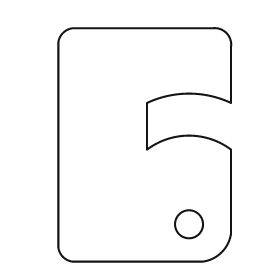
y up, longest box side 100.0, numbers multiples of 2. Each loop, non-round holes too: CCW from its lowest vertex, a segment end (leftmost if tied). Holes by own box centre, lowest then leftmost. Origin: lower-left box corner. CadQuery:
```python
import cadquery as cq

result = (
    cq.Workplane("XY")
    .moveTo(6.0, 0.0)
    .lineTo(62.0, 0.0)
    .threePointArc((70.0, 4.0), (74.0, 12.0))
    .lineTo(74.0, 48.0)
    .threePointArc((56.0, 54.0), (38.0, 48.0))
    .lineTo(38.0, 68.0)
    .threePointArc((56.0, 72.0), (74.0, 68.0))
    .lineTo(74.0, 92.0)
    .threePointArc((72.0, 98.0), (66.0, 100.0))
    .lineTo(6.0, 100.0)
    .threePointArc((2.0, 98.0), (0.0, 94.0))
    .lineTo(0.0, 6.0)
    .threePointArc((2.0, 2.0), (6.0, 0.0))
    .close()
    .moveTo(56.0, 16.0)
    .circle(6.0)
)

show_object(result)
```